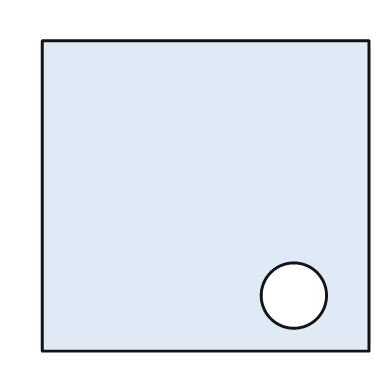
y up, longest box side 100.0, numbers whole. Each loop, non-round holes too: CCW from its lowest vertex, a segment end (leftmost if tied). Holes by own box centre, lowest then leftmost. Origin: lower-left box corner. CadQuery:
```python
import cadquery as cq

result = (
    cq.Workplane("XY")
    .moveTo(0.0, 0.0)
    .lineTo(100.0, 0.0)
    .lineTo(100.0, 95.0)
    .lineTo(0.0, 95.0)
    .close()
    .moveTo(77.0, 17.0)
    .circle(10.0)
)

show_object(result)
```